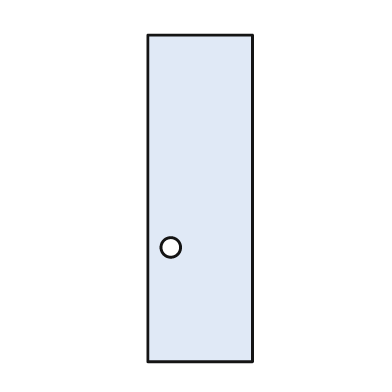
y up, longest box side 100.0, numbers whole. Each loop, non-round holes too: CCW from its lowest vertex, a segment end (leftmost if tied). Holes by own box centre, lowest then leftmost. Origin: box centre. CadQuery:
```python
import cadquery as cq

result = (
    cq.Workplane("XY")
    .moveTo(-16.0, -50.0)
    .lineTo(16.0, -50.0)
    .lineTo(16.0, 50.0)
    .lineTo(-16.0, 50.0)
    .close()
    .moveTo(-9.0, -15.0)
    .circle(3.0)
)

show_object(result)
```